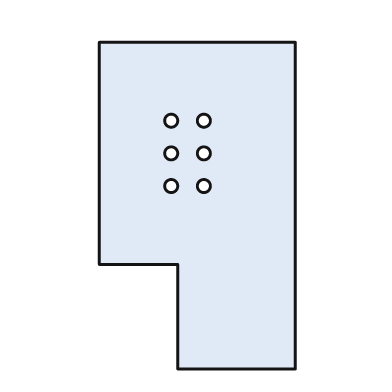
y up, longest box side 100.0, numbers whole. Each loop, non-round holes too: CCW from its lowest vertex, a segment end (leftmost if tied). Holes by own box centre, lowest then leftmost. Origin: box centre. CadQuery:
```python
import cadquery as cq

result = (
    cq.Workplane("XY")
    .moveTo(-6.0, -50.0)
    .lineTo(30.0, -50.0)
    .lineTo(30.0, 50.0)
    .lineTo(-30.0, 50.0)
    .lineTo(-30.0, -18.0)
    .lineTo(-6.0, -18.0)
    .close()
    .moveTo(-8.0, 6.0)
    .circle(2.0)
    .moveTo(2.0, 6.0)
    .circle(2.0)
    .moveTo(-8.0, 16.0)
    .circle(2.0)
    .moveTo(2.0, 16.0)
    .circle(2.0)
    .moveTo(-8.0, 26.0)
    .circle(2.0)
    .moveTo(2.0, 26.0)
    .circle(2.0)
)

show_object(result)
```